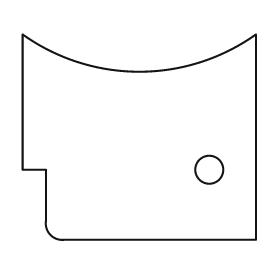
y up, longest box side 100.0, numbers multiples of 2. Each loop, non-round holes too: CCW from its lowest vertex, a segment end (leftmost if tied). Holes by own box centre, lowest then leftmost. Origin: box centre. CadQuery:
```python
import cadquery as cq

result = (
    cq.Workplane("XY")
    .moveTo(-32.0, -44.0)
    .lineTo(50.0, -44.0)
    .lineTo(50.0, 44.0)
    .threePointArc((0.0, 28.0), (-50.0, 44.0))
    .lineTo(-50.0, -14.0)
    .lineTo(-40.0, -14.0)
    .lineTo(-40.0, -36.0)
    .threePointArc((-38.0, -42.0), (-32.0, -44.0))
    .close()
    .moveTo(30.0, -14.0)
    .circle(6.0)
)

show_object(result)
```